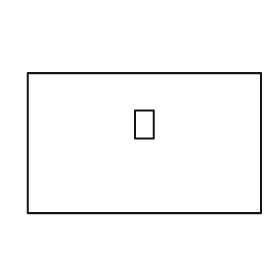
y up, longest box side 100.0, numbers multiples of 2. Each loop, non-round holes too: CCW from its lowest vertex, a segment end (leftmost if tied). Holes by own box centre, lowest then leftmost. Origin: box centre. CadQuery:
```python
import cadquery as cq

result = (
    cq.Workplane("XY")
    .moveTo(-50.0, -30.0)
    .lineTo(50.0, -30.0)
    .lineTo(50.0, 30.0)
    .lineTo(-50.0, 30.0)
    .close()
    .moveTo(-4.0, 2.0)
    .lineTo(4.0, 2.0)
    .lineTo(4.0, 14.0)
    .lineTo(-4.0, 14.0)
    .close()
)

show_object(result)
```